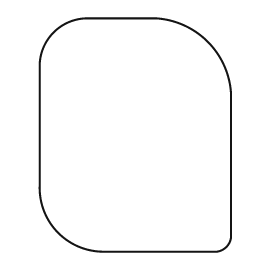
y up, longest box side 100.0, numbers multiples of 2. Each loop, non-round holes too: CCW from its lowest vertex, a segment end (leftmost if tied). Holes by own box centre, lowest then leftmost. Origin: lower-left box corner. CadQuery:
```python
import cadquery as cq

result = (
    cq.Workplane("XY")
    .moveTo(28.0, 0.0)
    .lineTo(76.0, 0.0)
    .threePointArc((80.0, 2.0), (82.0, 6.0))
    .lineTo(82.0, 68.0)
    .threePointArc((72.0, 90.0), (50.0, 100.0))
    .lineTo(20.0, 100.0)
    .threePointArc((6.0, 94.0), (0.0, 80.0))
    .lineTo(0.0, 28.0)
    .threePointArc((8.0, 8.0), (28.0, 0.0))
    .close()
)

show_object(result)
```